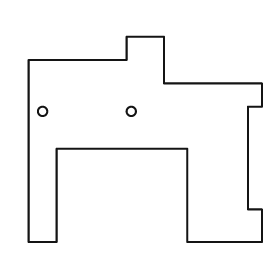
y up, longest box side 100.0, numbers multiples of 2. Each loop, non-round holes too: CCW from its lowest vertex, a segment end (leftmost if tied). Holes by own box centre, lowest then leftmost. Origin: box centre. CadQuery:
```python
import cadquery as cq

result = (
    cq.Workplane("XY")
    .moveTo(-50.0, -44.0)
    .lineTo(-38.0, -44.0)
    .lineTo(-38.0, -4.0)
    .lineTo(18.0, -4.0)
    .lineTo(18.0, -44.0)
    .lineTo(50.0, -44.0)
    .lineTo(50.0, -30.0)
    .lineTo(44.0, -30.0)
    .lineTo(44.0, 14.0)
    .lineTo(50.0, 14.0)
    .lineTo(50.0, 24.0)
    .lineTo(8.0, 24.0)
    .lineTo(8.0, 44.0)
    .lineTo(-8.0, 44.0)
    .lineTo(-8.0, 34.0)
    .lineTo(-50.0, 34.0)
    .close()
    .moveTo(-44.0, 12.0)
    .circle(2.0)
    .moveTo(-6.0, 12.0)
    .circle(2.0)
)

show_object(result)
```